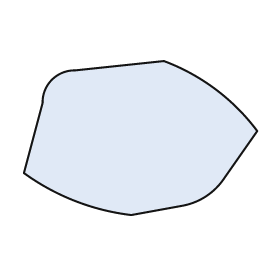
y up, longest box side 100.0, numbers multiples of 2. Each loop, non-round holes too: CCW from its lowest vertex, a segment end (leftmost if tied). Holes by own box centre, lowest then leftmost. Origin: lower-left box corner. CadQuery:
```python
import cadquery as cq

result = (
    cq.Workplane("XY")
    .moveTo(46.0, 0.0)
    .lineTo(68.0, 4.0)
    .threePointArc((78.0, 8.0), (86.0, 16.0))
    .lineTo(100.0, 36.0)
    .threePointArc((82.0, 54.0), (60.0, 66.0))
    .lineTo(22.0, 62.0)
    .threePointArc((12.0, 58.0), (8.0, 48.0))
    .lineTo(0.0, 18.0)
    .threePointArc((22.0, 6.0), (46.0, 0.0))
    .close()
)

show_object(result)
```